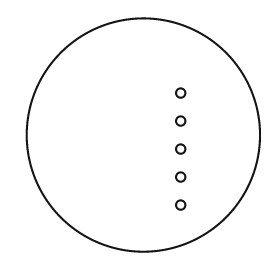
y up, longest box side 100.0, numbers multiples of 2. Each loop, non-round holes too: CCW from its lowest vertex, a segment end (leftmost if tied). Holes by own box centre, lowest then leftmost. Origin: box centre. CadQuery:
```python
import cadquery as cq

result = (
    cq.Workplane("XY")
    .moveTo(0.0, 0.0)
    .circle(50.0)
    .moveTo(16.0, -30.0)
    .circle(2.0)
    .moveTo(16.0, -18.0)
    .circle(2.0)
    .moveTo(16.0, -6.0)
    .circle(2.0)
    .moveTo(16.0, 6.0)
    .circle(2.0)
    .moveTo(16.0, 18.0)
    .circle(2.0)
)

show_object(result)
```